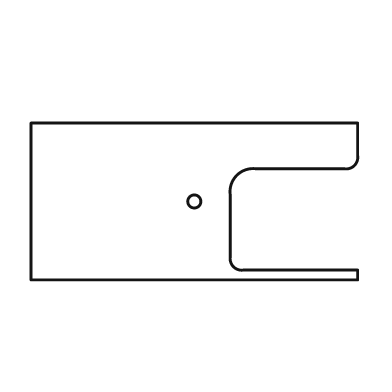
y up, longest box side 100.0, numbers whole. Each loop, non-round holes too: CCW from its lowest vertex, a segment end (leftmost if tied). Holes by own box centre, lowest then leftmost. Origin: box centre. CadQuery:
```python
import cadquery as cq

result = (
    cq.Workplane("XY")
    .moveTo(-50.0, -24.0)
    .lineTo(50.0, -24.0)
    .lineTo(50.0, -21.0)
    .lineTo(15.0, -21.0)
    .threePointArc((12.0, -20.0), (11.0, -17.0))
    .lineTo(11.0, 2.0)
    .threePointArc((13.0, 8.0), (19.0, 10.0))
    .lineTo(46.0, 10.0)
    .threePointArc((49.0, 11.0), (50.0, 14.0))
    .lineTo(50.0, 24.0)
    .lineTo(-50.0, 24.0)
    .close()
    .moveTo(0.0, 0.0)
    .circle(2.0)
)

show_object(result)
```